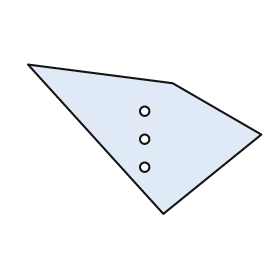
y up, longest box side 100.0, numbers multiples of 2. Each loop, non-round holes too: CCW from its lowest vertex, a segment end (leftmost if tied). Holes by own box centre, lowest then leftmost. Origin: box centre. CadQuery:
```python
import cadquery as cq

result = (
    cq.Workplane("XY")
    .moveTo(8.0, -32.0)
    .lineTo(50.0, 2.0)
    .lineTo(12.0, 24.0)
    .lineTo(-50.0, 32.0)
    .close()
    .moveTo(0.0, -12.0)
    .circle(2.0)
    .moveTo(0.0, 0.0)
    .circle(2.0)
    .moveTo(0.0, 12.0)
    .circle(2.0)
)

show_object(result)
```